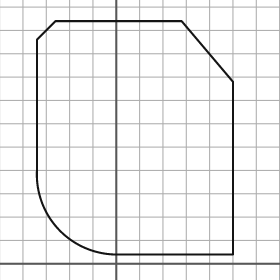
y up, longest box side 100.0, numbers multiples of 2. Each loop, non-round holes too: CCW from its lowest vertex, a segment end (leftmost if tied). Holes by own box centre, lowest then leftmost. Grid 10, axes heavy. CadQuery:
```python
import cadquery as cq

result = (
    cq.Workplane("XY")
    .moveTo(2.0, 4.0)
    .lineTo(50.0, 4.0)
    .lineTo(50.0, 78.0)
    .lineTo(28.0, 104.0)
    .lineTo(-26.0, 104.0)
    .lineTo(-34.0, 96.0)
    .lineTo(-34.0, 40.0)
    .threePointArc((-24.0, 14.0), (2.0, 4.0))
    .close()
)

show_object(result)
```